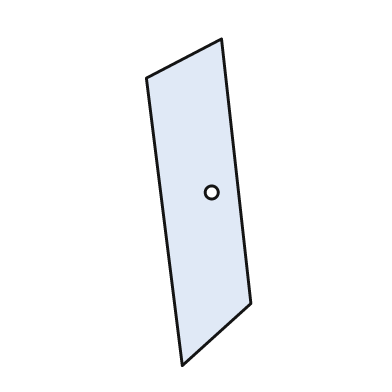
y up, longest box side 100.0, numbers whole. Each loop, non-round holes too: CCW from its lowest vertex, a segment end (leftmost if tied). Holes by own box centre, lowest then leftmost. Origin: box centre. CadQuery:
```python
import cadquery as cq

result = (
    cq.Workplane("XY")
    .moveTo(-5.0, -50.0)
    .lineTo(16.0, -31.0)
    .lineTo(7.0, 50.0)
    .lineTo(-16.0, 38.0)
    .close()
    .moveTo(4.0, 3.0)
    .circle(2.0)
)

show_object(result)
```